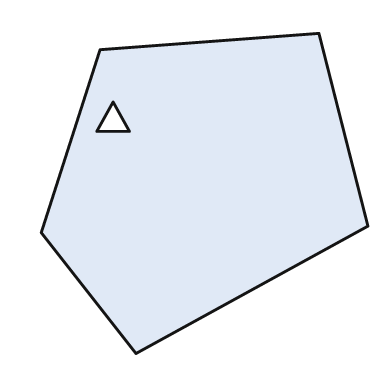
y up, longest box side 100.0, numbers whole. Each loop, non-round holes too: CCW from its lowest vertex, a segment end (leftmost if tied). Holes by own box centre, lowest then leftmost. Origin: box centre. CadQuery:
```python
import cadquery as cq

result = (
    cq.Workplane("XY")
    .moveTo(-21.0, -49.0)
    .lineTo(50.0, -10.0)
    .lineTo(35.0, 49.0)
    .lineTo(-32.0, 44.0)
    .lineTo(-50.0, -12.0)
    .close()
    .moveTo(-33.0, 19.0)
    .lineTo(-23.0, 19.0)
    .lineTo(-28.0, 28.0)
    .close()
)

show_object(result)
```